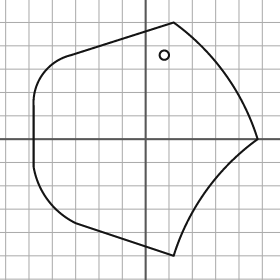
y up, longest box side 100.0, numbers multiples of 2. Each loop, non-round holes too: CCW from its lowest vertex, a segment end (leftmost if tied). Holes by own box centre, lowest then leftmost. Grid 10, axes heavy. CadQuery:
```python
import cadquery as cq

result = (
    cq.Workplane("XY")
    .moveTo(12.0, -50.0)
    .threePointArc((26.0, -22.0), (48.0, 0.0))
    .threePointArc((34.0, 28.0), (12.0, 50.0))
    .lineTo(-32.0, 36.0)
    .threePointArc((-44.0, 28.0), (-48.0, 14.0))
    .lineTo(-48.0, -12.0)
    .threePointArc((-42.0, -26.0), (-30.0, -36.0))
    .close()
    .moveTo(8.0, 36.0)
    .circle(2.0)
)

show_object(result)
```